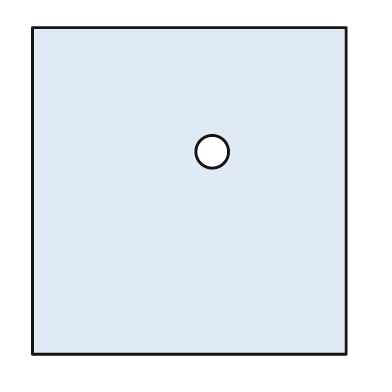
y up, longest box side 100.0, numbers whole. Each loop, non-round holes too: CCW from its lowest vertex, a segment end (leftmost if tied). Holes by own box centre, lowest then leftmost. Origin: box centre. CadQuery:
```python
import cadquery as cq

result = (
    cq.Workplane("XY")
    .moveTo(-48.0, -50.0)
    .lineTo(48.0, -50.0)
    .lineTo(48.0, 50.0)
    .lineTo(-48.0, 50.0)
    .close()
    .moveTo(7.0, 12.0)
    .circle(5.0)
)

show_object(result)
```